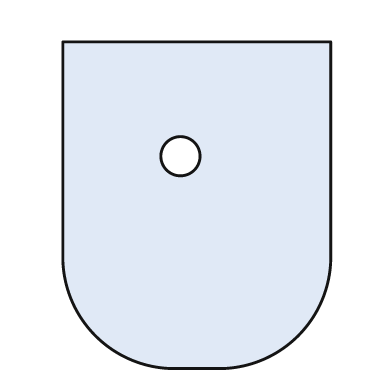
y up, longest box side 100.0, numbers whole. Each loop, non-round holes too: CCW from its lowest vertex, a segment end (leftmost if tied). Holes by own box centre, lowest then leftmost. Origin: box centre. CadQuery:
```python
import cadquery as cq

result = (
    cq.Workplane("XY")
    .moveTo(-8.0, -50.0)
    .lineTo(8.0, -50.0)
    .threePointArc((31.0, -40.0), (41.0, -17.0))
    .lineTo(41.0, 50.0)
    .lineTo(-41.0, 50.0)
    .lineTo(-41.0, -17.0)
    .threePointArc((-31.0, -40.0), (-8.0, -50.0))
    .close()
    .moveTo(-5.0, 15.0)
    .circle(6.0)
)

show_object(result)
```